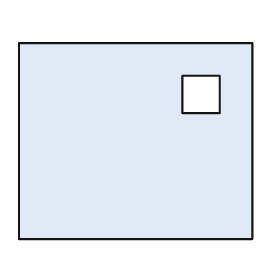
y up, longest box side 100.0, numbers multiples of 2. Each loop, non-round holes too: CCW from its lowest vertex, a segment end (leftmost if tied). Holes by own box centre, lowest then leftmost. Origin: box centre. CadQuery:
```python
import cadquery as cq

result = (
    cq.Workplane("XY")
    .moveTo(-50.0, -42.0)
    .lineTo(50.0, -42.0)
    .lineTo(50.0, 42.0)
    .lineTo(-50.0, 42.0)
    .close()
    .moveTo(20.0, 12.0)
    .lineTo(36.0, 12.0)
    .lineTo(36.0, 28.0)
    .lineTo(20.0, 28.0)
    .close()
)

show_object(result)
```